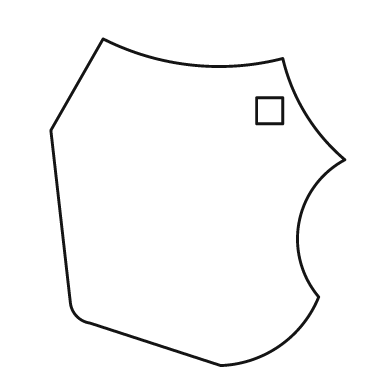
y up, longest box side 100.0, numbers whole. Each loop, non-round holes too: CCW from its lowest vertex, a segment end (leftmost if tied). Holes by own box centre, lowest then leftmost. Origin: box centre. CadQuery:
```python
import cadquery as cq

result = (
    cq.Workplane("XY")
    .moveTo(7.0, -50.0)
    .threePointArc((25.0, -44.0), (37.0, -29.0))
    .threePointArc((31.0, -6.0), (45.0, 13.0))
    .threePointArc((33.0, 27.0), (26.0, 44.0))
    .threePointArc((-2.0, 42.0), (-29.0, 50.0))
    .lineTo(-45.0, 22.0)
    .lineTo(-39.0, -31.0)
    .threePointArc((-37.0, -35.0), (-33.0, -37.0))
    .close()
    .moveTo(18.0, 24.0)
    .lineTo(26.0, 24.0)
    .lineTo(26.0, 32.0)
    .lineTo(18.0, 32.0)
    .close()
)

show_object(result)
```